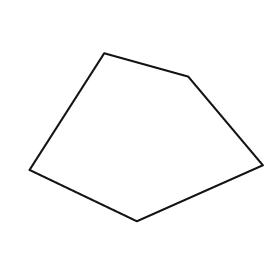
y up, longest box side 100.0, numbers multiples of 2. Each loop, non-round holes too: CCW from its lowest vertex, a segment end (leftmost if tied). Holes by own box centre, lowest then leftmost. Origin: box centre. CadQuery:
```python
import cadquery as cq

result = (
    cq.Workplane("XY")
    .moveTo(-4.0, -36.0)
    .lineTo(50.0, -12.0)
    .lineTo(18.0, 26.0)
    .lineTo(-18.0, 36.0)
    .lineTo(-50.0, -14.0)
    .close()
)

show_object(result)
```